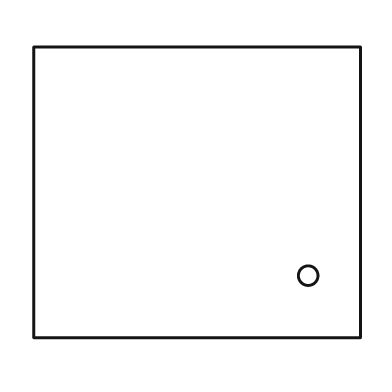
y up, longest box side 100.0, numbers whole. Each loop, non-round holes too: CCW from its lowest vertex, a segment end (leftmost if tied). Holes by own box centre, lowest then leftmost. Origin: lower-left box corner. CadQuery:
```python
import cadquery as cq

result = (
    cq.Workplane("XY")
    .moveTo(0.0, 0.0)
    .lineTo(100.0, 0.0)
    .lineTo(100.0, 89.0)
    .lineTo(0.0, 89.0)
    .close()
    .moveTo(84.0, 19.0)
    .circle(3.0)
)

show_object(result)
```